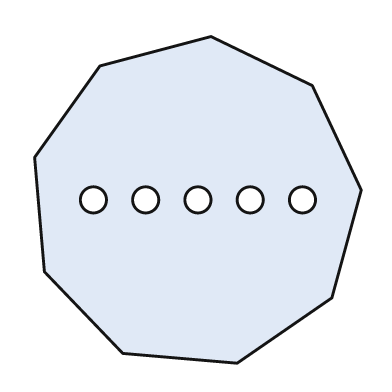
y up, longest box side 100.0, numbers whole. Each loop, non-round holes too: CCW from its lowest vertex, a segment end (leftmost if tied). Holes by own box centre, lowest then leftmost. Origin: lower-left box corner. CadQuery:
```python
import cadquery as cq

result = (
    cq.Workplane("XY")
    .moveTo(62.0, 0.0)
    .lineTo(91.0, 20.0)
    .lineTo(100.0, 53.0)
    .lineTo(85.0, 85.0)
    .lineTo(54.0, 100.0)
    .lineTo(20.0, 91.0)
    .lineTo(0.0, 63.0)
    .lineTo(3.0, 28.0)
    .lineTo(27.0, 3.0)
    .close()
    .moveTo(18.0, 50.0)
    .circle(4.0)
    .moveTo(34.0, 50.0)
    .circle(4.0)
    .moveTo(50.0, 50.0)
    .circle(4.0)
    .moveTo(66.0, 50.0)
    .circle(4.0)
    .moveTo(82.0, 50.0)
    .circle(4.0)
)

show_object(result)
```